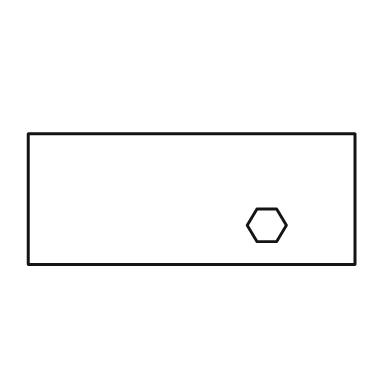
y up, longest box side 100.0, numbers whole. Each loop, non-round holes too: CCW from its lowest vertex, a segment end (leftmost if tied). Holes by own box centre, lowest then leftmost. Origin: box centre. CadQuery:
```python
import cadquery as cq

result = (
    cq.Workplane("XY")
    .moveTo(-50.0, -20.0)
    .lineTo(50.0, -20.0)
    .lineTo(50.0, 20.0)
    .lineTo(-50.0, 20.0)
    .close()
    .moveTo(20.0, -13.0)
    .lineTo(26.0, -13.0)
    .lineTo(29.0, -8.0)
    .lineTo(26.0, -3.0)
    .lineTo(20.0, -3.0)
    .lineTo(17.0, -8.0)
    .close()
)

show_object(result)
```